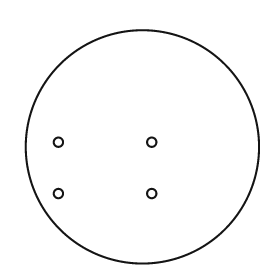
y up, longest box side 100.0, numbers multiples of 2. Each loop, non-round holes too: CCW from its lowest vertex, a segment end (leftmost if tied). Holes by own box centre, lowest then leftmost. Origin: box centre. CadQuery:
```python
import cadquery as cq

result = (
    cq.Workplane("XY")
    .moveTo(0.0, 0.0)
    .circle(50.0)
    .moveTo(-36.0, -20.0)
    .circle(2.0)
    .moveTo(4.0, -20.0)
    .circle(2.0)
    .moveTo(-36.0, 2.0)
    .circle(2.0)
    .moveTo(4.0, 2.0)
    .circle(2.0)
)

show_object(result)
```